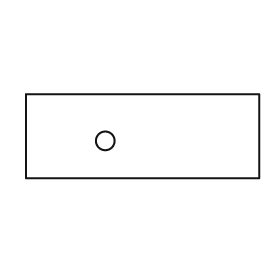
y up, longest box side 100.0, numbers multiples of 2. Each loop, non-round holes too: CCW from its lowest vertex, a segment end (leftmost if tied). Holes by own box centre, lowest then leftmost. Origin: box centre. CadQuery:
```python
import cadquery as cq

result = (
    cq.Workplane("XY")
    .moveTo(-50.0, -18.0)
    .lineTo(50.0, -18.0)
    .lineTo(50.0, 18.0)
    .lineTo(-50.0, 18.0)
    .close()
    .moveTo(-16.0, -2.0)
    .circle(4.0)
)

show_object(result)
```